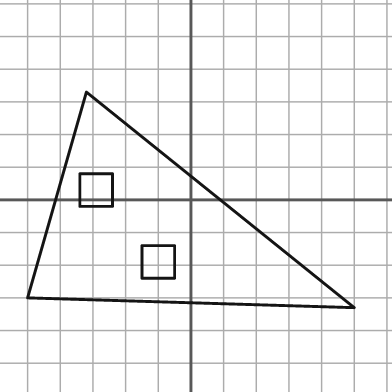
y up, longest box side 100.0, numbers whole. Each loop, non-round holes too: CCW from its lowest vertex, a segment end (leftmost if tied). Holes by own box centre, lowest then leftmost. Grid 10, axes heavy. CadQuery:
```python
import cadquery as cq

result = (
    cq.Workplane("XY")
    .moveTo(50.0, -33.0)
    .lineTo(-32.0, 33.0)
    .lineTo(-50.0, -30.0)
    .close()
    .moveTo(-15.0, -24.0)
    .lineTo(-5.0, -24.0)
    .lineTo(-5.0, -14.0)
    .lineTo(-15.0, -14.0)
    .close()
    .moveTo(-34.0, -2.0)
    .lineTo(-24.0, -2.0)
    .lineTo(-24.0, 8.0)
    .lineTo(-34.0, 8.0)
    .close()
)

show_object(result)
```